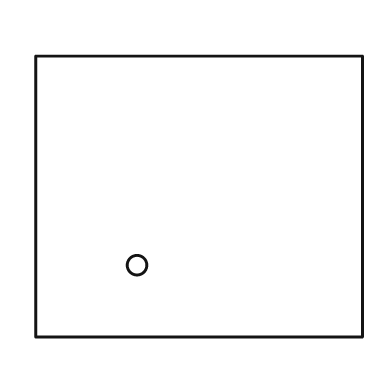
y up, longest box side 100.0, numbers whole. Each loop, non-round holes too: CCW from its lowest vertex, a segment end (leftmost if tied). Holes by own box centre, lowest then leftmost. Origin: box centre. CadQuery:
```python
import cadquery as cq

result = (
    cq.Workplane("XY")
    .moveTo(-50.0, -43.0)
    .lineTo(50.0, -43.0)
    .lineTo(50.0, 43.0)
    .lineTo(-50.0, 43.0)
    .close()
    .moveTo(-19.0, -21.0)
    .circle(3.0)
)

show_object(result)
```